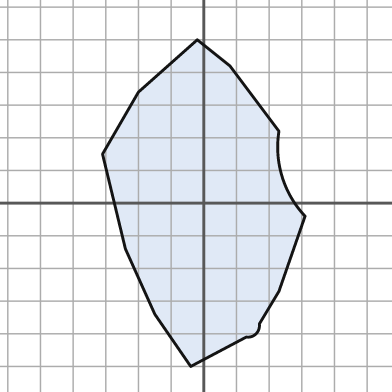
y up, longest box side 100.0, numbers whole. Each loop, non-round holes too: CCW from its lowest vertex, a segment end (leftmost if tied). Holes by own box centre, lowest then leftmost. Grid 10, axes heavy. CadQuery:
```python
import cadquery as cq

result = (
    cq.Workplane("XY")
    .moveTo(-4.0, -50.0)
    .lineTo(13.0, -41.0)
    .threePointArc((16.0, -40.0), (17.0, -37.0))
    .lineTo(23.0, -27.0)
    .lineTo(31.0, -4.0)
    .threePointArc((24.0, 8.0), (23.0, 22.0))
    .lineTo(8.0, 42.0)
    .lineTo(-2.0, 50.0)
    .lineTo(-20.0, 34.0)
    .lineTo(-31.0, 15.0)
    .lineTo(-24.0, -14.0)
    .lineTo(-15.0, -34.0)
    .close()
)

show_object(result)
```